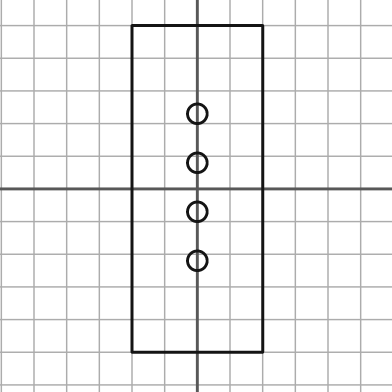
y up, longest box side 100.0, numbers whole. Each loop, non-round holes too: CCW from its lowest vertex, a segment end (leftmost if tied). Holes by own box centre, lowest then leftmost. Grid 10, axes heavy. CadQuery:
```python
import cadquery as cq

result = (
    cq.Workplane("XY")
    .moveTo(-20.0, -50.0)
    .lineTo(20.0, -50.0)
    .lineTo(20.0, 50.0)
    .lineTo(-20.0, 50.0)
    .close()
    .moveTo(0.0, -22.0)
    .circle(3.0)
    .moveTo(0.0, -7.0)
    .circle(3.0)
    .moveTo(0.0, 8.0)
    .circle(3.0)
    .moveTo(0.0, 23.0)
    .circle(3.0)
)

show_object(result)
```